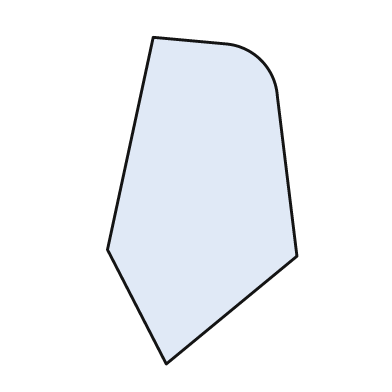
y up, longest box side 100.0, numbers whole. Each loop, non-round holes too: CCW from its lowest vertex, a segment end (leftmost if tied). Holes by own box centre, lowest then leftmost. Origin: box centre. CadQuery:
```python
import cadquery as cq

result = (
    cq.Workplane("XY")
    .moveTo(-11.0, -50.0)
    .lineTo(29.0, -17.0)
    .lineTo(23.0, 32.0)
    .threePointArc((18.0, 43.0), (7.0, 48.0))
    .lineTo(-15.0, 50.0)
    .lineTo(-29.0, -15.0)
    .close()
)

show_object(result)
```